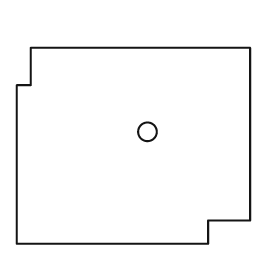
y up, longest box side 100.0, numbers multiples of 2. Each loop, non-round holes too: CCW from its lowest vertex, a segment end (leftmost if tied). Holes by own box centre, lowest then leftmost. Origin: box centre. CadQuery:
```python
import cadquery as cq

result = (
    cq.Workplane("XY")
    .moveTo(-50.0, -42.0)
    .lineTo(32.0, -42.0)
    .lineTo(32.0, -32.0)
    .lineTo(50.0, -32.0)
    .lineTo(50.0, 42.0)
    .lineTo(-44.0, 42.0)
    .lineTo(-44.0, 26.0)
    .lineTo(-50.0, 26.0)
    .close()
    .moveTo(6.0, 6.0)
    .circle(4.0)
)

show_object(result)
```